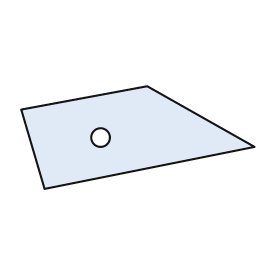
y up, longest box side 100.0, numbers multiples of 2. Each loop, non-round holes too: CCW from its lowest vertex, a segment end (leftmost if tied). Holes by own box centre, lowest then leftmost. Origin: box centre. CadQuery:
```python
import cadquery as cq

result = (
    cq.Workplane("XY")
    .moveTo(-40.0, -22.0)
    .lineTo(50.0, -4.0)
    .lineTo(4.0, 22.0)
    .lineTo(-50.0, 12.0)
    .close()
    .moveTo(-16.0, 0.0)
    .circle(4.0)
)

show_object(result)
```